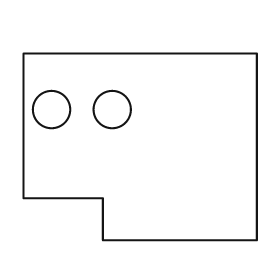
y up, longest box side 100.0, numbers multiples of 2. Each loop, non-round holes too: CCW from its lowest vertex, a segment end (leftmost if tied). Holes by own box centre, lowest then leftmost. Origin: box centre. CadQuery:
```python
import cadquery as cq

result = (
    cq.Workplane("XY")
    .moveTo(-16.0, -40.0)
    .lineTo(50.0, -40.0)
    .lineTo(50.0, 40.0)
    .lineTo(-50.0, 40.0)
    .lineTo(-50.0, -22.0)
    .lineTo(-16.0, -22.0)
    .close()
    .moveTo(-38.0, 16.0)
    .circle(8.0)
    .moveTo(-12.0, 16.0)
    .circle(8.0)
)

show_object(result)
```